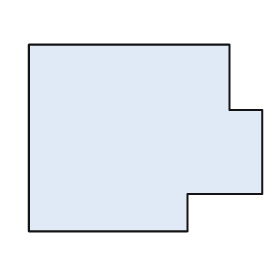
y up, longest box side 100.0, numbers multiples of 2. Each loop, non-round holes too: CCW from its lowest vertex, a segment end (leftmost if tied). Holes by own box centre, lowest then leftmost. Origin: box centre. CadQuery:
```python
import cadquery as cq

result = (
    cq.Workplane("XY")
    .moveTo(-50.0, -40.0)
    .lineTo(18.0, -40.0)
    .lineTo(18.0, -24.0)
    .lineTo(50.0, -24.0)
    .lineTo(50.0, 12.0)
    .lineTo(36.0, 12.0)
    .lineTo(36.0, 40.0)
    .lineTo(-50.0, 40.0)
    .close()
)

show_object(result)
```